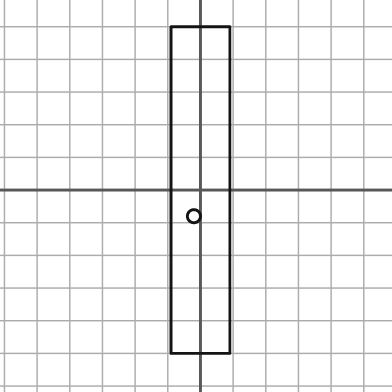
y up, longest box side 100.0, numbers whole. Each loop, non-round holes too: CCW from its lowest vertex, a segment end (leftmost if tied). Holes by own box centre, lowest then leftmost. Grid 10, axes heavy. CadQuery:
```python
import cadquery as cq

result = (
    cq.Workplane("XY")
    .moveTo(-9.0, -50.0)
    .lineTo(9.0, -50.0)
    .lineTo(9.0, 50.0)
    .lineTo(-9.0, 50.0)
    .close()
    .moveTo(-2.0, -8.0)
    .circle(2.0)
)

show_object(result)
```